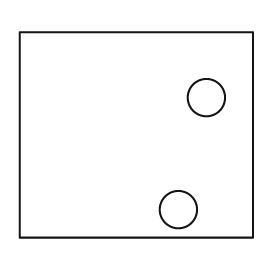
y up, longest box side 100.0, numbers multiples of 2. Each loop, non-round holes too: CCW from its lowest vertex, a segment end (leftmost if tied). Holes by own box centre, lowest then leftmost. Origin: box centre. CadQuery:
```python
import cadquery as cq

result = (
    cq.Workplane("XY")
    .moveTo(-50.0, -44.0)
    .lineTo(50.0, -44.0)
    .lineTo(50.0, 44.0)
    .lineTo(-50.0, 44.0)
    .close()
    .moveTo(18.0, -32.0)
    .circle(8.0)
    .moveTo(30.0, 16.0)
    .circle(8.0)
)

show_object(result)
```